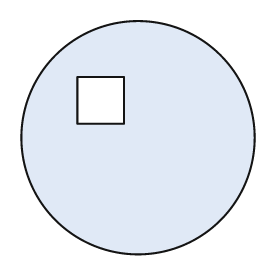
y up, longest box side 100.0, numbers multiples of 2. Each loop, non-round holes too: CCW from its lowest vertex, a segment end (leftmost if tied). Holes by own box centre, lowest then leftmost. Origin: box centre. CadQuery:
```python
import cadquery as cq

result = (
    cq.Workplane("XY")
    .moveTo(0.0, 0.0)
    .circle(50.0)
    .moveTo(-26.0, 6.0)
    .lineTo(-6.0, 6.0)
    .lineTo(-6.0, 26.0)
    .lineTo(-26.0, 26.0)
    .close()
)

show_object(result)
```